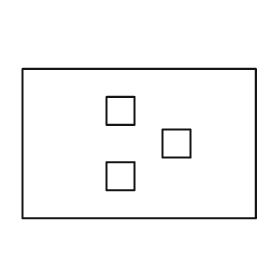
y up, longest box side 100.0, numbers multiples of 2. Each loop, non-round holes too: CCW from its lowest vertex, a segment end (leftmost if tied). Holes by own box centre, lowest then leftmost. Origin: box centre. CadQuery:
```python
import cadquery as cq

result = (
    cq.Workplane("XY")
    .moveTo(-50.0, -32.0)
    .lineTo(50.0, -32.0)
    .lineTo(50.0, 32.0)
    .lineTo(-50.0, 32.0)
    .close()
    .moveTo(-14.0, -20.0)
    .lineTo(-2.0, -20.0)
    .lineTo(-2.0, -8.0)
    .lineTo(-14.0, -8.0)
    .close()
    .moveTo(10.0, -6.0)
    .lineTo(22.0, -6.0)
    .lineTo(22.0, 6.0)
    .lineTo(10.0, 6.0)
    .close()
    .moveTo(-14.0, 8.0)
    .lineTo(-2.0, 8.0)
    .lineTo(-2.0, 20.0)
    .lineTo(-14.0, 20.0)
    .close()
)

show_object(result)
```